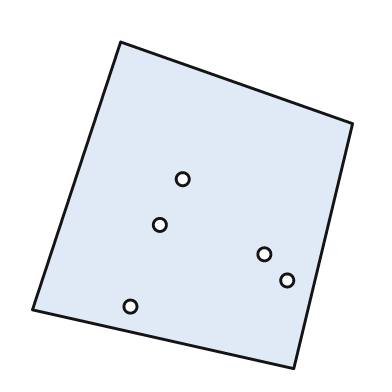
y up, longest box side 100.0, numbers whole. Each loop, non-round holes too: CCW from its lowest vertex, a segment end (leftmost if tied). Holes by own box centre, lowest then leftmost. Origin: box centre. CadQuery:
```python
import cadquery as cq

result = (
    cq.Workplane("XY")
    .moveTo(31.0, -50.0)
    .lineTo(49.0, 25.0)
    .lineTo(-22.0, 50.0)
    .lineTo(-49.0, -32.0)
    .close()
    .moveTo(-19.0, -31.0)
    .circle(2.0)
    .moveTo(29.0, -23.0)
    .circle(2.0)
    .moveTo(22.0, -15.0)
    .circle(2.0)
    .moveTo(-10.0, -6.0)
    .circle(2.0)
    .moveTo(-3.0, 8.0)
    .circle(2.0)
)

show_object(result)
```